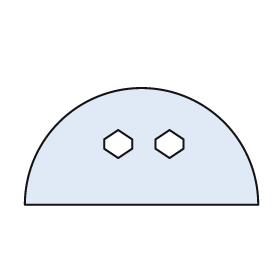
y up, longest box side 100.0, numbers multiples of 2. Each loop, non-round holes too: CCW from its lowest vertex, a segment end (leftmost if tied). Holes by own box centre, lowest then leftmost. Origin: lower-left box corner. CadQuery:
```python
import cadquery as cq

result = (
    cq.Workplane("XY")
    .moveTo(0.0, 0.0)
    .lineTo(100.0, 0.0)
    .threePointArc((50.0, 50.0), (0.0, 0.0))
    .close()
    .moveTo(40.0, 20.0)
    .lineTo(46.0, 24.0)
    .lineTo(46.0, 28.0)
    .lineTo(40.0, 32.0)
    .lineTo(34.0, 28.0)
    .lineTo(34.0, 24.0)
    .close()
    .moveTo(62.0, 20.0)
    .lineTo(68.0, 24.0)
    .lineTo(68.0, 28.0)
    .lineTo(62.0, 32.0)
    .lineTo(56.0, 28.0)
    .lineTo(56.0, 24.0)
    .close()
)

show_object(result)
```